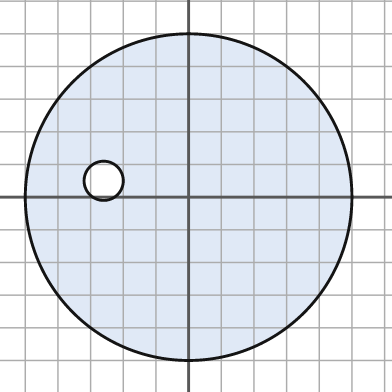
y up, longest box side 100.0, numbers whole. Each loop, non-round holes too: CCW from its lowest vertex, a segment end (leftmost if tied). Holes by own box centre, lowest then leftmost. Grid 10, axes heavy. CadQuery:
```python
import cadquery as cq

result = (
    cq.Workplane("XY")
    .moveTo(0.0, 0.0)
    .circle(50.0)
    .moveTo(-26.0, 5.0)
    .circle(6.0)
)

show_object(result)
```